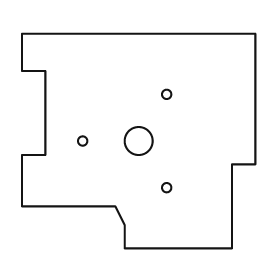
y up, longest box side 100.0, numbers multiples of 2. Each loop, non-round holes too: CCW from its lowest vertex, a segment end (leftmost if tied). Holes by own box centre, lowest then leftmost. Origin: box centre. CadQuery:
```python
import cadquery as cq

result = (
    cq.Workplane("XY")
    .moveTo(-6.0, -46.0)
    .lineTo(40.0, -46.0)
    .lineTo(40.0, -10.0)
    .lineTo(50.0, -10.0)
    .lineTo(50.0, 46.0)
    .lineTo(-50.0, 46.0)
    .lineTo(-50.0, 30.0)
    .lineTo(-40.0, 30.0)
    .lineTo(-40.0, -6.0)
    .lineTo(-50.0, -6.0)
    .lineTo(-50.0, -28.0)
    .lineTo(-10.0, -28.0)
    .lineTo(-6.0, -36.0)
    .close()
    .moveTo(12.0, -20.0)
    .circle(2.0)
    .moveTo(-24.0, 0.0)
    .circle(2.0)
    .moveTo(0.0, 0.0)
    .circle(6.0)
    .moveTo(12.0, 20.0)
    .circle(2.0)
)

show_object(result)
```